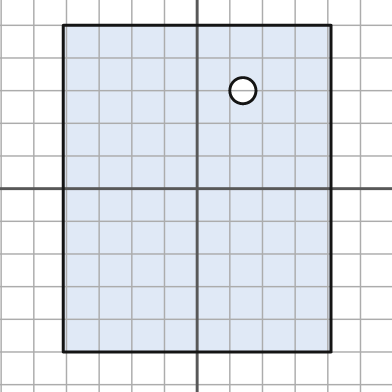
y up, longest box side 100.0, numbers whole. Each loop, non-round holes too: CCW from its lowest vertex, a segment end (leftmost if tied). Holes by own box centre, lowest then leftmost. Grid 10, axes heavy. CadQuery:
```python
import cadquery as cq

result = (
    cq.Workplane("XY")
    .moveTo(-41.0, -50.0)
    .lineTo(41.0, -50.0)
    .lineTo(41.0, 50.0)
    .lineTo(-41.0, 50.0)
    .close()
    .moveTo(14.0, 30.0)
    .circle(4.0)
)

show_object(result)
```